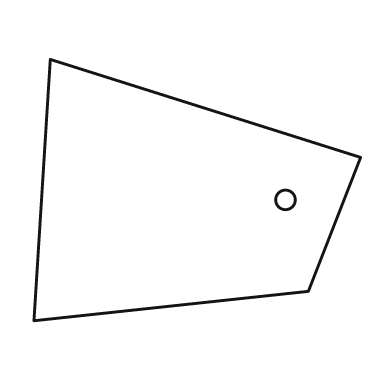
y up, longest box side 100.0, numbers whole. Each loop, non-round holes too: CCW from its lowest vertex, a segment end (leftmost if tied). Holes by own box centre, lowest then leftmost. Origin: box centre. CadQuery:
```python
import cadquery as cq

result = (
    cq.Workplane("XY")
    .moveTo(-50.0, -40.0)
    .lineTo(34.0, -31.0)
    .lineTo(50.0, 10.0)
    .lineTo(-45.0, 40.0)
    .close()
    .moveTo(27.0, -3.0)
    .circle(3.0)
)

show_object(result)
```